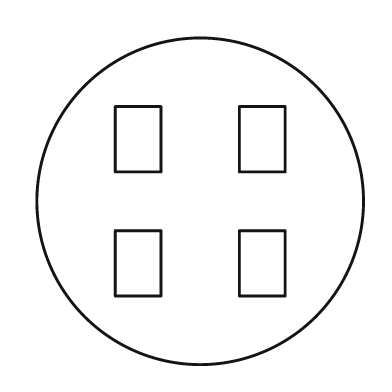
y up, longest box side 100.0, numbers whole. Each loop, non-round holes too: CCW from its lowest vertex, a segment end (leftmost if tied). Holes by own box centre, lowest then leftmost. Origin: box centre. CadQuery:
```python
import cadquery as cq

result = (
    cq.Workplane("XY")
    .moveTo(0.0, 0.0)
    .circle(50.0)
    .moveTo(-26.0, -29.0)
    .lineTo(-12.0, -29.0)
    .lineTo(-12.0, -9.0)
    .lineTo(-26.0, -9.0)
    .close()
    .moveTo(12.0, -29.0)
    .lineTo(26.0, -29.0)
    .lineTo(26.0, -9.0)
    .lineTo(12.0, -9.0)
    .close()
    .moveTo(-26.0, 9.0)
    .lineTo(-12.0, 9.0)
    .lineTo(-12.0, 29.0)
    .lineTo(-26.0, 29.0)
    .close()
    .moveTo(12.0, 9.0)
    .lineTo(26.0, 9.0)
    .lineTo(26.0, 29.0)
    .lineTo(12.0, 29.0)
    .close()
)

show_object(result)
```